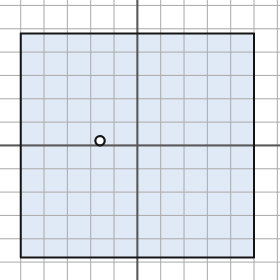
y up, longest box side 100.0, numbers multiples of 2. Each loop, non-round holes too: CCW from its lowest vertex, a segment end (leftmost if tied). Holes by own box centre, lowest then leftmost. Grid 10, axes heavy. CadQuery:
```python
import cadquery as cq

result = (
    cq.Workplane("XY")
    .moveTo(-50.0, -48.0)
    .lineTo(50.0, -48.0)
    .lineTo(50.0, 48.0)
    .lineTo(-50.0, 48.0)
    .close()
    .moveTo(-16.0, 2.0)
    .circle(2.0)
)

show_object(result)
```